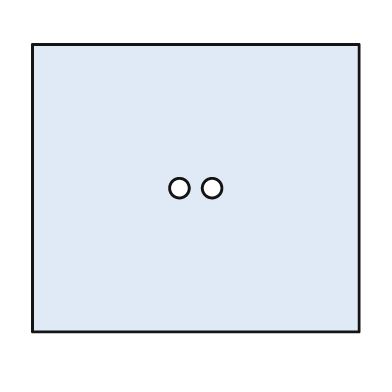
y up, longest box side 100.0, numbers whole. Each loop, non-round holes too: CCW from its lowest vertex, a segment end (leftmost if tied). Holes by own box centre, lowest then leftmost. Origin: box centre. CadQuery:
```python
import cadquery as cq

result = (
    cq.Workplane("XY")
    .moveTo(-50.0, -44.0)
    .lineTo(50.0, -44.0)
    .lineTo(50.0, 44.0)
    .lineTo(-50.0, 44.0)
    .close()
    .moveTo(-5.0, 0.0)
    .circle(3.0)
    .moveTo(5.0, 0.0)
    .circle(3.0)
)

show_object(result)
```